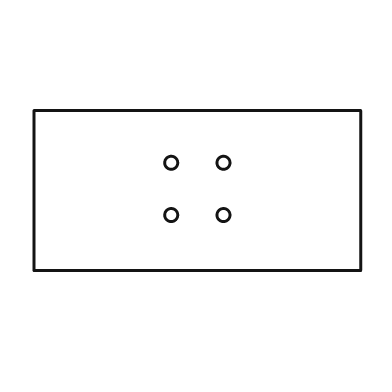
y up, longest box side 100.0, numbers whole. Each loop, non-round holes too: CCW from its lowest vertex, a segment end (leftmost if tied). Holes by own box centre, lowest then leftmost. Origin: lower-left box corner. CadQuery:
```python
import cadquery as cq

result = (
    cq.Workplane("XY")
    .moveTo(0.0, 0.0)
    .lineTo(100.0, 0.0)
    .lineTo(100.0, 49.0)
    .lineTo(0.0, 49.0)
    .close()
    .moveTo(42.0, 17.0)
    .circle(2.0)
    .moveTo(58.0, 17.0)
    .circle(2.0)
    .moveTo(42.0, 33.0)
    .circle(2.0)
    .moveTo(58.0, 33.0)
    .circle(2.0)
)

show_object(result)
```